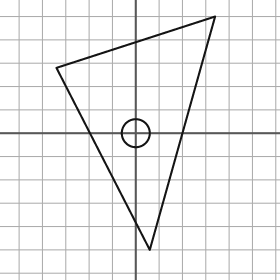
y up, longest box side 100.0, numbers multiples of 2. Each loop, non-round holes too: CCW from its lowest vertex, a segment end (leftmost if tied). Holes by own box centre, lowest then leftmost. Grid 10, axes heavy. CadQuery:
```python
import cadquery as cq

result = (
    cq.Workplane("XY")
    .moveTo(6.0, -50.0)
    .lineTo(34.0, 50.0)
    .lineTo(-34.0, 28.0)
    .close()
    .moveTo(0.0, 0.0)
    .circle(6.0)
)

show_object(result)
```